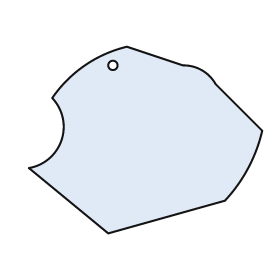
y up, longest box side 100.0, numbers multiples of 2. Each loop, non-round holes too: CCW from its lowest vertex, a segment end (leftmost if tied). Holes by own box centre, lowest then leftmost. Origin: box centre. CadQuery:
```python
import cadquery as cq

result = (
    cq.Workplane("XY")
    .moveTo(-16.0, -40.0)
    .lineTo(34.0, -26.0)
    .threePointArc((44.0, -12.0), (50.0, 4.0))
    .lineTo(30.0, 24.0)
    .threePointArc((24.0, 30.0), (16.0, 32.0))
    .lineTo(-8.0, 40.0)
    .threePointArc((-26.0, 32.0), (-40.0, 18.0))
    .threePointArc((-36.0, 0.0), (-50.0, -12.0))
    .close()
    .moveTo(-14.0, 32.0)
    .circle(2.0)
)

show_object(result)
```